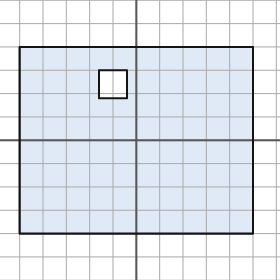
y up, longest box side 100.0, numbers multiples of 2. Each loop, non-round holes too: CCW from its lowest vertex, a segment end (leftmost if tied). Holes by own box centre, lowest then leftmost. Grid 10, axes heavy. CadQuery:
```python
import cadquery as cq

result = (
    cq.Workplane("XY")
    .moveTo(-50.0, -40.0)
    .lineTo(50.0, -40.0)
    .lineTo(50.0, 40.0)
    .lineTo(-50.0, 40.0)
    .close()
    .moveTo(-16.0, 18.0)
    .lineTo(-4.0, 18.0)
    .lineTo(-4.0, 30.0)
    .lineTo(-16.0, 30.0)
    .close()
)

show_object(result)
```